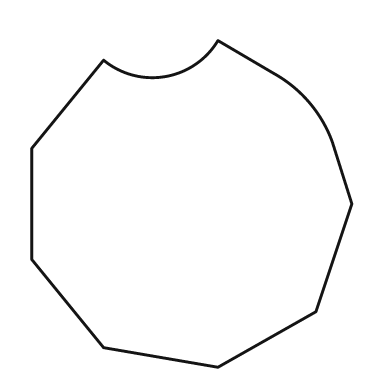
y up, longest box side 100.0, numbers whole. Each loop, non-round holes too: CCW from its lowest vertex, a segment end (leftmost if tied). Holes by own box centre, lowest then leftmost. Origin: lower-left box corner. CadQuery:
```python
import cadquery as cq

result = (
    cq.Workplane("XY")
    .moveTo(57.0, 0.0)
    .lineTo(87.0, 17.0)
    .lineTo(98.0, 50.0)
    .lineTo(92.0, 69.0)
    .threePointArc((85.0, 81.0), (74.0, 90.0))
    .lineTo(57.0, 100.0)
    .threePointArc((41.0, 89.0), (22.0, 94.0))
    .lineTo(0.0, 67.0)
    .lineTo(0.0, 33.0)
    .lineTo(22.0, 6.0)
    .close()
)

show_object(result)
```